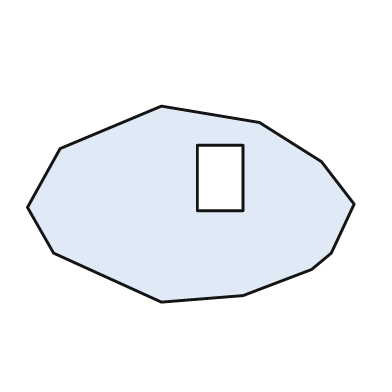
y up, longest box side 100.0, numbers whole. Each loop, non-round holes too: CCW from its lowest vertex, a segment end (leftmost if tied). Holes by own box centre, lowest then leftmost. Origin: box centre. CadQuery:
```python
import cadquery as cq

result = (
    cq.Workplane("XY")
    .moveTo(-9.0, -30.0)
    .lineTo(16.0, -28.0)
    .lineTo(37.0, -20.0)
    .lineTo(43.0, -15.0)
    .lineTo(50.0, 0.0)
    .lineTo(40.0, 13.0)
    .lineTo(21.0, 25.0)
    .lineTo(-9.0, 30.0)
    .lineTo(-40.0, 17.0)
    .lineTo(-50.0, -1.0)
    .lineTo(-42.0, -15.0)
    .close()
    .moveTo(2.0, -2.0)
    .lineTo(16.0, -2.0)
    .lineTo(16.0, 18.0)
    .lineTo(2.0, 18.0)
    .close()
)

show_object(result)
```